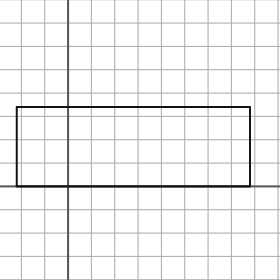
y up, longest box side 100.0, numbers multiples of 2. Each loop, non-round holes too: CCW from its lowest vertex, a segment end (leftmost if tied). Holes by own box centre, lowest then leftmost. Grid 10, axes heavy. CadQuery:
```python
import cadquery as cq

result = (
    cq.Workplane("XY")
    .moveTo(-22.0, 0.0)
    .lineTo(78.0, 0.0)
    .lineTo(78.0, 34.0)
    .lineTo(-22.0, 34.0)
    .close()
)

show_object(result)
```